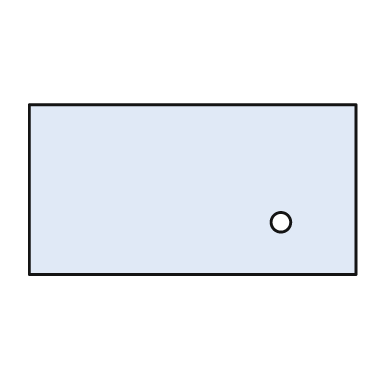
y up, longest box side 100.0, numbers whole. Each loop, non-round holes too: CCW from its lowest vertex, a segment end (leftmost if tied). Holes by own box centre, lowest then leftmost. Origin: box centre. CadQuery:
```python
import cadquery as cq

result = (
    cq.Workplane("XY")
    .moveTo(-50.0, -26.0)
    .lineTo(50.0, -26.0)
    .lineTo(50.0, 26.0)
    .lineTo(-50.0, 26.0)
    .close()
    .moveTo(27.0, -10.0)
    .circle(3.0)
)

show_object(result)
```